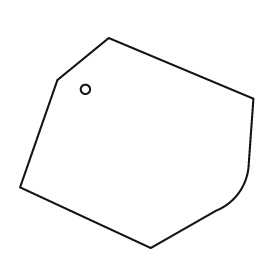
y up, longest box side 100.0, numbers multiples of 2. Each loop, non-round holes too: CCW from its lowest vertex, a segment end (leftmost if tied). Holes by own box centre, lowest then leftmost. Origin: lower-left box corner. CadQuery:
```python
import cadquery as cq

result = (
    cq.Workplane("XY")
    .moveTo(56.0, 0.0)
    .lineTo(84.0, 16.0)
    .threePointArc((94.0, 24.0), (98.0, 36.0))
    .lineTo(100.0, 64.0)
    .lineTo(38.0, 90.0)
    .lineTo(16.0, 72.0)
    .lineTo(0.0, 26.0)
    .close()
    .moveTo(28.0, 68.0)
    .circle(2.0)
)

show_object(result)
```